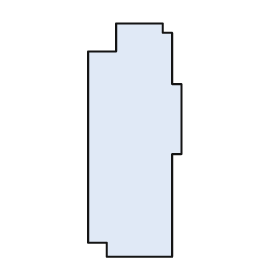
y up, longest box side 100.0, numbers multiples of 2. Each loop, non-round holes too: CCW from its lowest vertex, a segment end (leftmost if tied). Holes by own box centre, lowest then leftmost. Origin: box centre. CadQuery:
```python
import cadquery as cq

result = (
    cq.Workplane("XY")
    .moveTo(-12.0, -50.0)
    .lineTo(16.0, -50.0)
    .lineTo(16.0, -6.0)
    .lineTo(20.0, -6.0)
    .lineTo(20.0, 24.0)
    .lineTo(16.0, 24.0)
    .lineTo(16.0, 46.0)
    .lineTo(12.0, 46.0)
    .lineTo(12.0, 50.0)
    .lineTo(-8.0, 50.0)
    .lineTo(-8.0, 38.0)
    .lineTo(-20.0, 38.0)
    .lineTo(-20.0, -44.0)
    .lineTo(-12.0, -44.0)
    .close()
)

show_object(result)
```